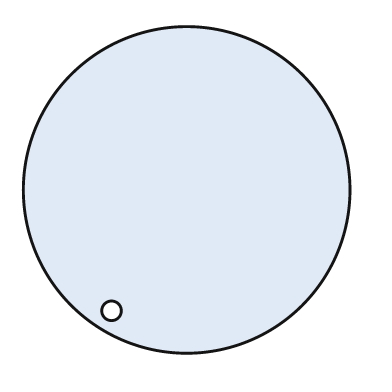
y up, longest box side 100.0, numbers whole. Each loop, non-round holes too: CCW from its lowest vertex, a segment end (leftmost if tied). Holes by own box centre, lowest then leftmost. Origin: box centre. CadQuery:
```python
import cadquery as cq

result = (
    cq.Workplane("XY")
    .moveTo(0.0, 0.0)
    .circle(50.0)
    .moveTo(-23.0, -37.0)
    .circle(3.0)
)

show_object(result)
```